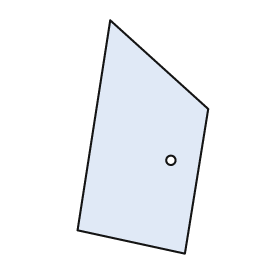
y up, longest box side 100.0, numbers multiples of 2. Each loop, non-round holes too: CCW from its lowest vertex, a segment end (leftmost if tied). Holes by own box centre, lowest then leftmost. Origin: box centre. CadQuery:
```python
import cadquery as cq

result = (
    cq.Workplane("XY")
    .moveTo(18.0, -50.0)
    .lineTo(28.0, 12.0)
    .lineTo(-14.0, 50.0)
    .lineTo(-28.0, -40.0)
    .close()
    .moveTo(12.0, -10.0)
    .circle(2.0)
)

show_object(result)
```